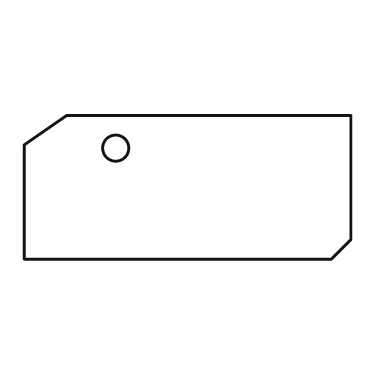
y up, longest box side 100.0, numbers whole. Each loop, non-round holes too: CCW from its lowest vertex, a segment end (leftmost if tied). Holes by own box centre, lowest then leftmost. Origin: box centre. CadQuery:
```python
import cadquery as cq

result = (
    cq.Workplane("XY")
    .moveTo(-50.0, -22.0)
    .lineTo(44.0, -22.0)
    .lineTo(50.0, -16.0)
    .lineTo(50.0, 22.0)
    .lineTo(-37.0, 22.0)
    .lineTo(-50.0, 13.0)
    .close()
    .moveTo(-22.0, 12.0)
    .circle(4.0)
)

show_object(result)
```